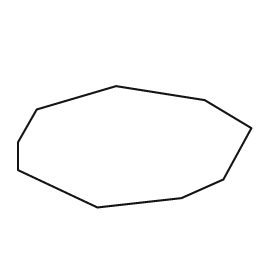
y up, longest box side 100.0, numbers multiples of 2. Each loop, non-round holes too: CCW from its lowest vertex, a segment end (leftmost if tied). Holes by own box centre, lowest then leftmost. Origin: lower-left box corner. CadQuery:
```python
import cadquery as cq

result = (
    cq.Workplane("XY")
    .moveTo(34.0, 0.0)
    .lineTo(70.0, 4.0)
    .lineTo(88.0, 12.0)
    .lineTo(100.0, 34.0)
    .lineTo(80.0, 46.0)
    .lineTo(42.0, 52.0)
    .lineTo(8.0, 42.0)
    .lineTo(0.0, 28.0)
    .lineTo(0.0, 16.0)
    .close()
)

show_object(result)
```